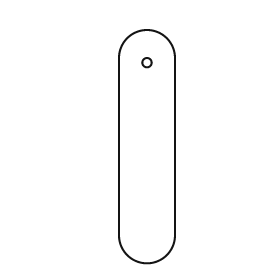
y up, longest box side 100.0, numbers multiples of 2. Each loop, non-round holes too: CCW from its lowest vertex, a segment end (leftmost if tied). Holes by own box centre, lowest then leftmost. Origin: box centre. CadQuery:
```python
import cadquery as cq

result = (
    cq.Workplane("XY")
    .moveTo(-12.0, -38.0)
    .threePointArc((0.0, -50.0), (12.0, -38.0))
    .lineTo(12.0, 38.0)
    .threePointArc((0.0, 50.0), (-12.0, 38.0))
    .close()
    .moveTo(0.0, 36.0)
    .circle(2.0)
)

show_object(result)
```